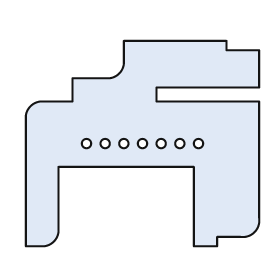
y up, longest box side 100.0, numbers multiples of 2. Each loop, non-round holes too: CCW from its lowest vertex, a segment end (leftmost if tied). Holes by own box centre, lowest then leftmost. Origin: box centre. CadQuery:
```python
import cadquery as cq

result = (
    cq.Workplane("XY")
    .moveTo(-50.0, -44.0)
    .lineTo(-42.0, -44.0)
    .threePointArc((-38.0, -42.0), (-36.0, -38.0))
    .lineTo(-36.0, -10.0)
    .lineTo(22.0, -10.0)
    .lineTo(22.0, -44.0)
    .lineTo(32.0, -44.0)
    .lineTo(32.0, -40.0)
    .lineTo(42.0, -40.0)
    .threePointArc((48.0, -38.0), (50.0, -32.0))
    .lineTo(50.0, 18.0)
    .lineTo(6.0, 18.0)
    .lineTo(6.0, 24.0)
    .lineTo(50.0, 24.0)
    .lineTo(50.0, 40.0)
    .lineTo(36.0, 40.0)
    .lineTo(36.0, 44.0)
    .lineTo(-8.0, 44.0)
    .lineTo(-8.0, 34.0)
    .threePointArc((-10.0, 30.0), (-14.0, 28.0))
    .lineTo(-30.0, 28.0)
    .lineTo(-30.0, 18.0)
    .lineTo(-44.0, 18.0)
    .threePointArc((-48.0, 16.0), (-50.0, 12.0))
    .close()
    .moveTo(-24.0, 0.0)
    .circle(2.0)
    .moveTo(-16.0, 0.0)
    .circle(2.0)
    .moveTo(-8.0, 0.0)
    .circle(2.0)
    .moveTo(0.0, 0.0)
    .circle(2.0)
    .moveTo(8.0, 0.0)
    .circle(2.0)
    .moveTo(16.0, 0.0)
    .circle(2.0)
    .moveTo(24.0, 0.0)
    .circle(2.0)
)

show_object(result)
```